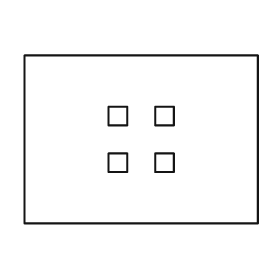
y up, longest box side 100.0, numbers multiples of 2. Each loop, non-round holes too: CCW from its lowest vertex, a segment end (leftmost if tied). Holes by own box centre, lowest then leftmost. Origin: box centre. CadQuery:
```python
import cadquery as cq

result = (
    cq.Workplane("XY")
    .moveTo(-50.0, -36.0)
    .lineTo(50.0, -36.0)
    .lineTo(50.0, 36.0)
    .lineTo(-50.0, 36.0)
    .close()
    .moveTo(-14.0, -14.0)
    .lineTo(-6.0, -14.0)
    .lineTo(-6.0, -6.0)
    .lineTo(-14.0, -6.0)
    .close()
    .moveTo(6.0, -14.0)
    .lineTo(14.0, -14.0)
    .lineTo(14.0, -6.0)
    .lineTo(6.0, -6.0)
    .close()
    .moveTo(-14.0, 6.0)
    .lineTo(-6.0, 6.0)
    .lineTo(-6.0, 14.0)
    .lineTo(-14.0, 14.0)
    .close()
    .moveTo(6.0, 6.0)
    .lineTo(14.0, 6.0)
    .lineTo(14.0, 14.0)
    .lineTo(6.0, 14.0)
    .close()
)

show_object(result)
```